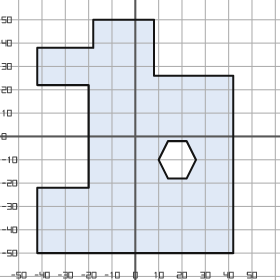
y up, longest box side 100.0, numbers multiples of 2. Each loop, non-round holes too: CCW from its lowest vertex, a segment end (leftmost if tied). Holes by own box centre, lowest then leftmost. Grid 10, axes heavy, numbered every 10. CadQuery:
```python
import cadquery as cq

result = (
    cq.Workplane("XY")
    .moveTo(-42.0, -50.0)
    .lineTo(42.0, -50.0)
    .lineTo(42.0, 26.0)
    .lineTo(8.0, 26.0)
    .lineTo(8.0, 50.0)
    .lineTo(-18.0, 50.0)
    .lineTo(-18.0, 38.0)
    .lineTo(-42.0, 38.0)
    .lineTo(-42.0, 22.0)
    .lineTo(-20.0, 22.0)
    .lineTo(-20.0, -22.0)
    .lineTo(-42.0, -22.0)
    .close()
    .moveTo(14.0, -18.0)
    .lineTo(22.0, -18.0)
    .lineTo(26.0, -10.0)
    .lineTo(22.0, -2.0)
    .lineTo(14.0, -2.0)
    .lineTo(10.0, -10.0)
    .close()
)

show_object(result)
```